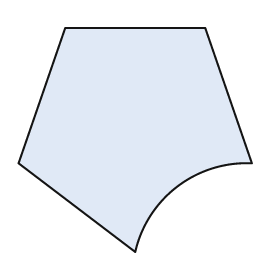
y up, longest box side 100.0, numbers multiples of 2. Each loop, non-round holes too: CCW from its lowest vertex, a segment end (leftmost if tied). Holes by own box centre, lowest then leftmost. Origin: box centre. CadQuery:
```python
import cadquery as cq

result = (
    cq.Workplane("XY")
    .moveTo(0.0, -48.0)
    .threePointArc((18.0, -20.0), (50.0, -10.0))
    .lineTo(30.0, 48.0)
    .lineTo(-30.0, 48.0)
    .lineTo(-50.0, -10.0)
    .close()
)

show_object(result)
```